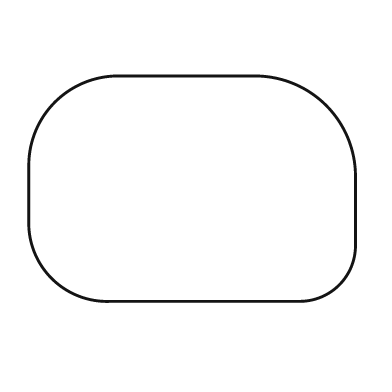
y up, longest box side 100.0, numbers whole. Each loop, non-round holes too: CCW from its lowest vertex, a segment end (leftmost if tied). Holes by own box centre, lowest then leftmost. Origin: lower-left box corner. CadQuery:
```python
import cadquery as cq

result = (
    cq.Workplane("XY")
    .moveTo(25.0, 0.0)
    .lineTo(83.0, 0.0)
    .threePointArc((95.0, 5.0), (100.0, 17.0))
    .lineTo(100.0, 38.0)
    .threePointArc((91.0, 60.0), (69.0, 69.0))
    .lineTo(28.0, 69.0)
    .threePointArc((8.0, 61.0), (0.0, 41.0))
    .lineTo(0.0, 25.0)
    .threePointArc((7.0, 7.0), (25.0, 0.0))
    .close()
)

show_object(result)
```